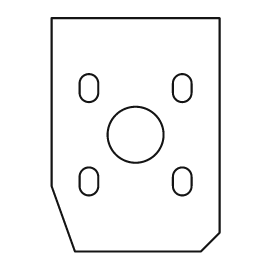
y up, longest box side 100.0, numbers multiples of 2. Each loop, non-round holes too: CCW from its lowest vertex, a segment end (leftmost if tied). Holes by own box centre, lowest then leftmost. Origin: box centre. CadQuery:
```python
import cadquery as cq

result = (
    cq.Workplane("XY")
    .moveTo(-26.0, -50.0)
    .lineTo(28.0, -50.0)
    .lineTo(36.0, -42.0)
    .lineTo(36.0, 50.0)
    .lineTo(-36.0, 50.0)
    .lineTo(-36.0, -22.0)
    .close()
    .moveTo(-24.0, -22.0)
    .threePointArc((-20.0, -26.0), (-16.0, -22.0))
    .lineTo(-16.0, -18.0)
    .threePointArc((-20.0, -14.0), (-24.0, -18.0))
    .close()
    .moveTo(16.0, -22.0)
    .threePointArc((20.0, -26.0), (24.0, -22.0))
    .lineTo(24.0, -18.0)
    .threePointArc((20.0, -14.0), (16.0, -18.0))
    .close()
    .moveTo(0.0, 0.0)
    .circle(12.0)
    .moveTo(-24.0, 18.0)
    .threePointArc((-20.0, 14.0), (-16.0, 18.0))
    .lineTo(-16.0, 22.0)
    .threePointArc((-20.0, 26.0), (-24.0, 22.0))
    .close()
    .moveTo(16.0, 18.0)
    .threePointArc((20.0, 14.0), (24.0, 18.0))
    .lineTo(24.0, 22.0)
    .threePointArc((20.0, 26.0), (16.0, 22.0))
    .close()
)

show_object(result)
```